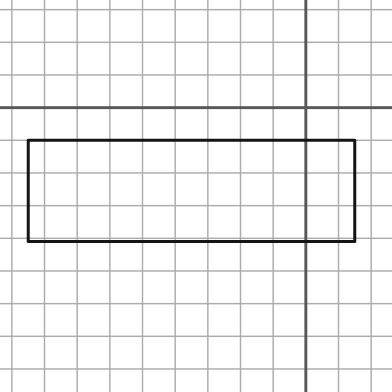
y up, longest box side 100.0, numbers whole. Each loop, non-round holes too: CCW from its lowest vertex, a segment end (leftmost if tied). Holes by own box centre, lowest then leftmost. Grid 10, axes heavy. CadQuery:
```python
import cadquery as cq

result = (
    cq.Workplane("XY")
    .moveTo(-85.0, -41.0)
    .lineTo(15.0, -41.0)
    .lineTo(15.0, -10.0)
    .lineTo(-85.0, -10.0)
    .close()
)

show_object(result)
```